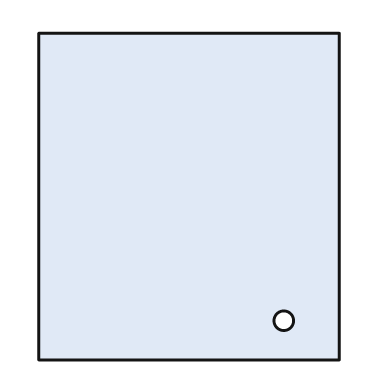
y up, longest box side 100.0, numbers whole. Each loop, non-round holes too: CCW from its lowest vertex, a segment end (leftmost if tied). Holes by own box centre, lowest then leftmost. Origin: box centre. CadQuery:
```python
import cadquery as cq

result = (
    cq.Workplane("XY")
    .moveTo(-46.0, -50.0)
    .lineTo(46.0, -50.0)
    .lineTo(46.0, 50.0)
    .lineTo(-46.0, 50.0)
    .close()
    .moveTo(29.0, -38.0)
    .circle(3.0)
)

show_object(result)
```